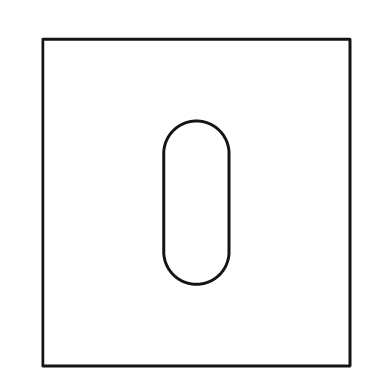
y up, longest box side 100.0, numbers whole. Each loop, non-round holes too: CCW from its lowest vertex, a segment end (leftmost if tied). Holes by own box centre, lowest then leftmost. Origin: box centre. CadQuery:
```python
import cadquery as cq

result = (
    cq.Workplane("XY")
    .moveTo(-47.0, -50.0)
    .lineTo(47.0, -50.0)
    .lineTo(47.0, 50.0)
    .lineTo(-47.0, 50.0)
    .close()
    .moveTo(-10.0, -15.0)
    .threePointArc((0.0, -25.0), (10.0, -15.0))
    .lineTo(10.0, 15.0)
    .threePointArc((0.0, 25.0), (-10.0, 15.0))
    .close()
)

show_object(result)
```